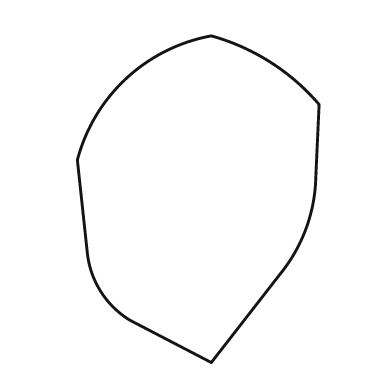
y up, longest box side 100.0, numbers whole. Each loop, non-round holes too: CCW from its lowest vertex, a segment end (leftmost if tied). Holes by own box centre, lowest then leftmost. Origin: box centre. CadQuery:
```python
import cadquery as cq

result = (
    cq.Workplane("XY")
    .moveTo(4.0, -50.0)
    .lineTo(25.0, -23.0)
    .threePointArc((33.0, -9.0), (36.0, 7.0))
    .lineTo(37.0, 29.0)
    .threePointArc((22.0, 42.0), (4.0, 50.0))
    .threePointArc((-22.0, 37.0), (-37.0, 12.0))
    .lineTo(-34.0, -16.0)
    .threePointArc((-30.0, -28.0), (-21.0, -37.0))
    .close()
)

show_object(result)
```